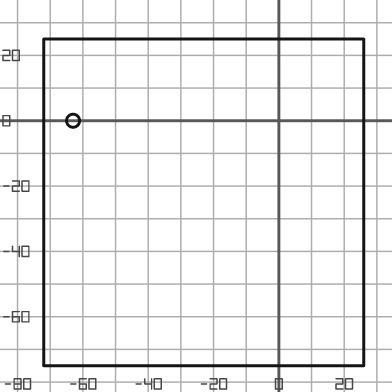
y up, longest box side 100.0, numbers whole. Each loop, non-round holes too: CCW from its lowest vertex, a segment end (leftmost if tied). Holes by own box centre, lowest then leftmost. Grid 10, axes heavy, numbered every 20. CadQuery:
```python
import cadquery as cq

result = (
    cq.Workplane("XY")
    .moveTo(-72.0, -75.0)
    .lineTo(26.0, -75.0)
    .lineTo(26.0, 25.0)
    .lineTo(-72.0, 25.0)
    .close()
    .moveTo(-63.0, 0.0)
    .circle(2.0)
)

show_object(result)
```